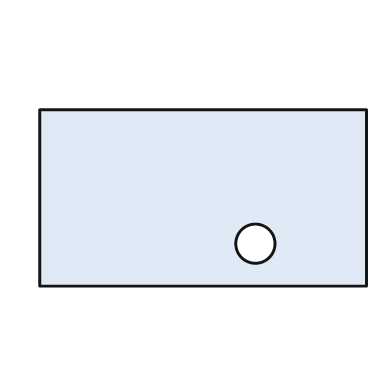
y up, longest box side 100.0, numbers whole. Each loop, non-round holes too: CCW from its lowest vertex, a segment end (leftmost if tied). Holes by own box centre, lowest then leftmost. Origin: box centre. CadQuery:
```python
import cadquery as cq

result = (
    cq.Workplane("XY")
    .moveTo(-50.0, -27.0)
    .lineTo(50.0, -27.0)
    .lineTo(50.0, 27.0)
    .lineTo(-50.0, 27.0)
    .close()
    .moveTo(16.0, -14.0)
    .circle(6.0)
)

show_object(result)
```